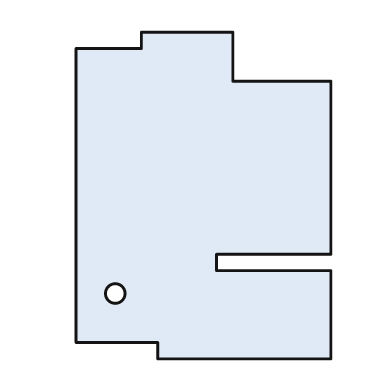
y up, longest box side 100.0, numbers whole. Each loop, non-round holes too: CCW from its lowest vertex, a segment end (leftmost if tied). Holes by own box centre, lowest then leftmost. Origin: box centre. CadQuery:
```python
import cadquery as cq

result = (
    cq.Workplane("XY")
    .moveTo(-14.0, -50.0)
    .lineTo(39.0, -50.0)
    .lineTo(39.0, -23.0)
    .lineTo(4.0, -23.0)
    .lineTo(4.0, -18.0)
    .lineTo(39.0, -18.0)
    .lineTo(39.0, 35.0)
    .lineTo(9.0, 35.0)
    .lineTo(9.0, 50.0)
    .lineTo(-19.0, 50.0)
    .lineTo(-19.0, 45.0)
    .lineTo(-39.0, 45.0)
    .lineTo(-39.0, -45.0)
    .lineTo(-14.0, -45.0)
    .close()
    .moveTo(-27.0, -30.0)
    .circle(3.0)
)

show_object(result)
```